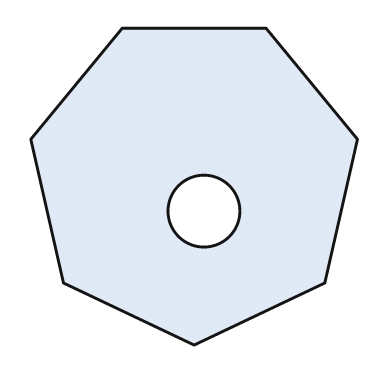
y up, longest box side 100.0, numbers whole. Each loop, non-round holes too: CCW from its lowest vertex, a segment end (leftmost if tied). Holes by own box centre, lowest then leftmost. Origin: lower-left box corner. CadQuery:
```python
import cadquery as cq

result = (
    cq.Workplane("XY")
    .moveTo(50.0, 0.0)
    .lineTo(90.0, 19.0)
    .lineTo(100.0, 63.0)
    .lineTo(72.0, 97.0)
    .lineTo(28.0, 97.0)
    .lineTo(0.0, 63.0)
    .lineTo(10.0, 19.0)
    .close()
    .moveTo(53.0, 41.0)
    .circle(11.0)
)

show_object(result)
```